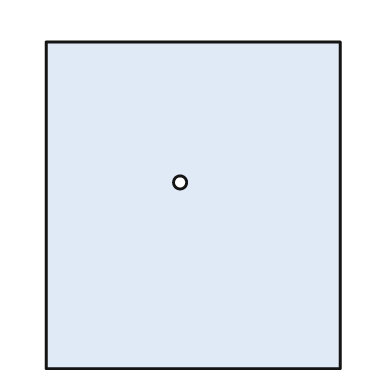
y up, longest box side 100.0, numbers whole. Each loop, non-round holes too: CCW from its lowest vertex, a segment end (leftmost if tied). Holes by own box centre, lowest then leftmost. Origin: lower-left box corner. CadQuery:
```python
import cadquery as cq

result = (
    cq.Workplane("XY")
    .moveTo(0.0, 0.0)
    .lineTo(90.0, 0.0)
    .lineTo(90.0, 100.0)
    .lineTo(0.0, 100.0)
    .close()
    .moveTo(41.0, 57.0)
    .circle(2.0)
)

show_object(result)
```